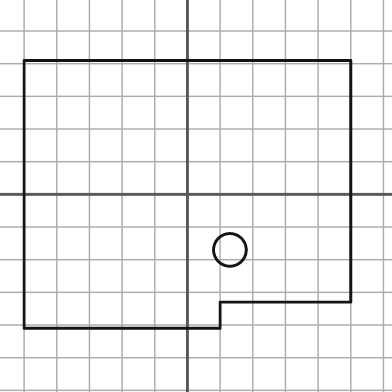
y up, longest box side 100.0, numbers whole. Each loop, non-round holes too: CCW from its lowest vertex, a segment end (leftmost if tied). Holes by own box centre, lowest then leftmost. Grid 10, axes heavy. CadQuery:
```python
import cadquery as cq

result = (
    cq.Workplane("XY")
    .moveTo(-50.0, -41.0)
    .lineTo(10.0, -41.0)
    .lineTo(10.0, -33.0)
    .lineTo(50.0, -33.0)
    .lineTo(50.0, 41.0)
    .lineTo(-50.0, 41.0)
    .close()
    .moveTo(13.0, -17.0)
    .circle(5.0)
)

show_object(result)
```